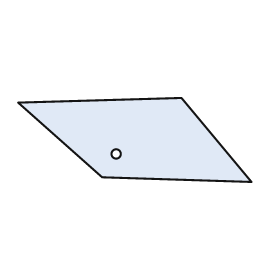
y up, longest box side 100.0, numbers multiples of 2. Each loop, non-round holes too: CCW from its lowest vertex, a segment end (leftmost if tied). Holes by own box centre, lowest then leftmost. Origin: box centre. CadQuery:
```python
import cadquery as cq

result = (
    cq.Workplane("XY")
    .moveTo(50.0, -18.0)
    .lineTo(20.0, 18.0)
    .lineTo(-50.0, 16.0)
    .lineTo(-14.0, -16.0)
    .close()
    .moveTo(-8.0, -6.0)
    .circle(2.0)
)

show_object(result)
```